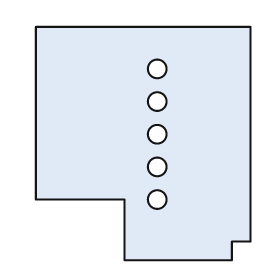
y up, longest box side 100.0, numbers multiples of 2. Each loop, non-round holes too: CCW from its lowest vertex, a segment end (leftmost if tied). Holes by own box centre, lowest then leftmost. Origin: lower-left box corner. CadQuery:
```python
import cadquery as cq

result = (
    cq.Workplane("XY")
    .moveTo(38.0, 0.0)
    .lineTo(84.0, 0.0)
    .lineTo(84.0, 8.0)
    .lineTo(92.0, 8.0)
    .lineTo(92.0, 100.0)
    .lineTo(0.0, 100.0)
    .lineTo(0.0, 26.0)
    .lineTo(38.0, 26.0)
    .close()
    .moveTo(52.0, 26.0)
    .circle(4.0)
    .moveTo(52.0, 40.0)
    .circle(4.0)
    .moveTo(52.0, 54.0)
    .circle(4.0)
    .moveTo(52.0, 68.0)
    .circle(4.0)
    .moveTo(52.0, 82.0)
    .circle(4.0)
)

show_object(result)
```